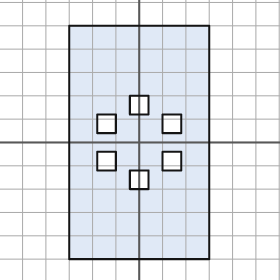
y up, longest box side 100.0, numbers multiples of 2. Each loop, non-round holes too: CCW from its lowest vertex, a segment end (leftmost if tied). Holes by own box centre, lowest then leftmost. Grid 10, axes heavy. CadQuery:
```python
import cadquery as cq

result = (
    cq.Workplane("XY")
    .moveTo(-30.0, -50.0)
    .lineTo(30.0, -50.0)
    .lineTo(30.0, 50.0)
    .lineTo(-30.0, 50.0)
    .close()
    .moveTo(-4.0, -20.0)
    .lineTo(4.0, -20.0)
    .lineTo(4.0, -12.0)
    .lineTo(-4.0, -12.0)
    .close()
    .moveTo(-18.0, -12.0)
    .lineTo(-10.0, -12.0)
    .lineTo(-10.0, -4.0)
    .lineTo(-18.0, -4.0)
    .close()
    .moveTo(10.0, -12.0)
    .lineTo(18.0, -12.0)
    .lineTo(18.0, -4.0)
    .lineTo(10.0, -4.0)
    .close()
    .moveTo(-18.0, 4.0)
    .lineTo(-10.0, 4.0)
    .lineTo(-10.0, 12.0)
    .lineTo(-18.0, 12.0)
    .close()
    .moveTo(10.0, 4.0)
    .lineTo(18.0, 4.0)
    .lineTo(18.0, 12.0)
    .lineTo(10.0, 12.0)
    .close()
    .moveTo(-4.0, 12.0)
    .lineTo(4.0, 12.0)
    .lineTo(4.0, 20.0)
    .lineTo(-4.0, 20.0)
    .close()
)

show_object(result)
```